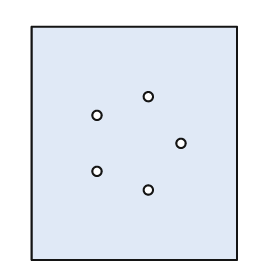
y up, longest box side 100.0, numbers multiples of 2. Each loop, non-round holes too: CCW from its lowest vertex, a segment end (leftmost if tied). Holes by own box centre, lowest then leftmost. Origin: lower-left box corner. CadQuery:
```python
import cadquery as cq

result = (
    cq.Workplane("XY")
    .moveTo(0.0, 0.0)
    .lineTo(88.0, 0.0)
    .lineTo(88.0, 100.0)
    .lineTo(0.0, 100.0)
    .close()
    .moveTo(50.0, 30.0)
    .circle(2.0)
    .moveTo(28.0, 38.0)
    .circle(2.0)
    .moveTo(64.0, 50.0)
    .circle(2.0)
    .moveTo(28.0, 62.0)
    .circle(2.0)
    .moveTo(50.0, 70.0)
    .circle(2.0)
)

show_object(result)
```